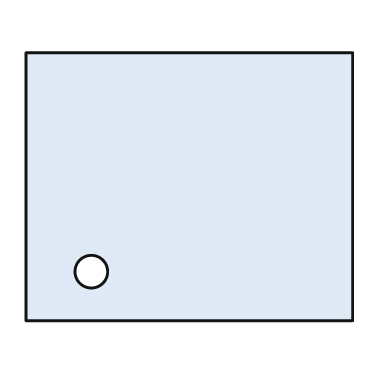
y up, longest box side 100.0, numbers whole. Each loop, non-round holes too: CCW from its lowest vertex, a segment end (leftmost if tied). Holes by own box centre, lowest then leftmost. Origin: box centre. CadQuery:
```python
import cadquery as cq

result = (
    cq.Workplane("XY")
    .moveTo(-50.0, -41.0)
    .lineTo(50.0, -41.0)
    .lineTo(50.0, 41.0)
    .lineTo(-50.0, 41.0)
    .close()
    .moveTo(-30.0, -26.0)
    .circle(5.0)
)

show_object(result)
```